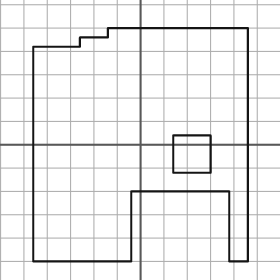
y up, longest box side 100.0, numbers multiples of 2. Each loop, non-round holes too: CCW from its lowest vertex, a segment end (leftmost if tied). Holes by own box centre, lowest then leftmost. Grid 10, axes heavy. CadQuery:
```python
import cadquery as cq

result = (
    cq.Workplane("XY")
    .moveTo(-46.0, -50.0)
    .lineTo(-4.0, -50.0)
    .lineTo(-4.0, -20.0)
    .lineTo(38.0, -20.0)
    .lineTo(38.0, -50.0)
    .lineTo(46.0, -50.0)
    .lineTo(46.0, 50.0)
    .lineTo(-14.0, 50.0)
    .lineTo(-14.0, 46.0)
    .lineTo(-26.0, 46.0)
    .lineTo(-26.0, 42.0)
    .lineTo(-46.0, 42.0)
    .close()
    .moveTo(14.0, -12.0)
    .lineTo(30.0, -12.0)
    .lineTo(30.0, 4.0)
    .lineTo(14.0, 4.0)
    .close()
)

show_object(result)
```